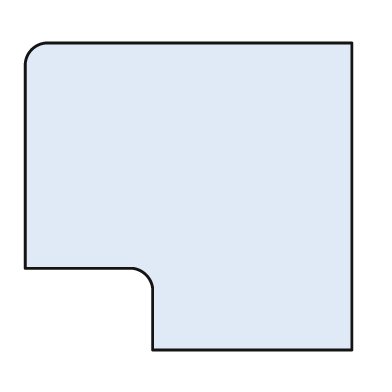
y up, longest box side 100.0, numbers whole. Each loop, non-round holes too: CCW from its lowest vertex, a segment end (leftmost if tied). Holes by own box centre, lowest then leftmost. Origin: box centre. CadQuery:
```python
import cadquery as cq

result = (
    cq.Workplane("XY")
    .moveTo(-11.0, -47.0)
    .lineTo(50.0, -47.0)
    .lineTo(50.0, 47.0)
    .lineTo(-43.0, 47.0)
    .threePointArc((-48.0, 45.0), (-50.0, 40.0))
    .lineTo(-50.0, -22.0)
    .lineTo(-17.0, -22.0)
    .threePointArc((-13.0, -24.0), (-11.0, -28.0))
    .close()
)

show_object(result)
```